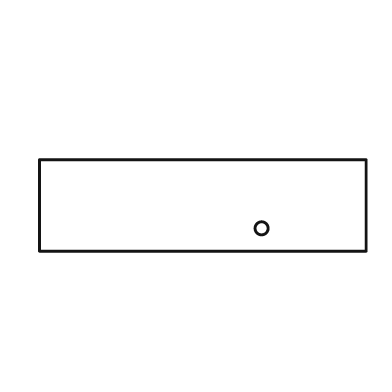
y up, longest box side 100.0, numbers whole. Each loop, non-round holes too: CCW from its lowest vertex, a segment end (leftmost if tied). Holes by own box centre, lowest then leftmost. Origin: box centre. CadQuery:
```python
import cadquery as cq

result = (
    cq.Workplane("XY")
    .moveTo(-50.0, -14.0)
    .lineTo(50.0, -14.0)
    .lineTo(50.0, 14.0)
    .lineTo(-50.0, 14.0)
    .close()
    .moveTo(18.0, -7.0)
    .circle(2.0)
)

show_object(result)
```